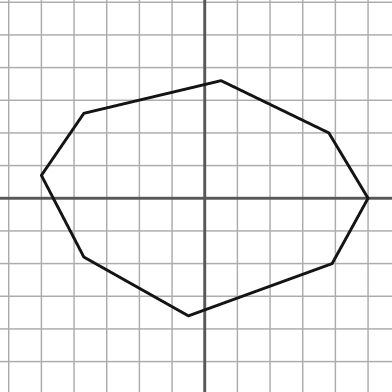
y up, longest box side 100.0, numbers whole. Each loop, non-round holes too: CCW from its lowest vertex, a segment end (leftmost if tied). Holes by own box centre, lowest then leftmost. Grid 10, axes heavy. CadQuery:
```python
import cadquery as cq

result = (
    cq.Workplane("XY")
    .moveTo(-5.0, -36.0)
    .lineTo(39.0, -20.0)
    .lineTo(50.0, 0.0)
    .lineTo(38.0, 20.0)
    .lineTo(5.0, 36.0)
    .lineTo(-37.0, 26.0)
    .lineTo(-50.0, 7.0)
    .lineTo(-37.0, -18.0)
    .close()
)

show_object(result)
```